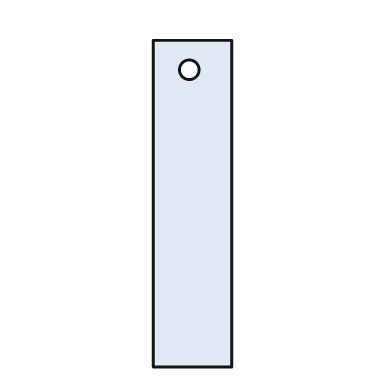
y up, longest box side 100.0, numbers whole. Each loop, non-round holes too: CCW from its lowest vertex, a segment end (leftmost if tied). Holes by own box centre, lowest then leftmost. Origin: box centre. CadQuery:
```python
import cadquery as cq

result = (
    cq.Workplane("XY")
    .moveTo(-12.0, -50.0)
    .lineTo(12.0, -50.0)
    .lineTo(12.0, 50.0)
    .lineTo(-12.0, 50.0)
    .close()
    .moveTo(-1.0, 41.0)
    .circle(3.0)
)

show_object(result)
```